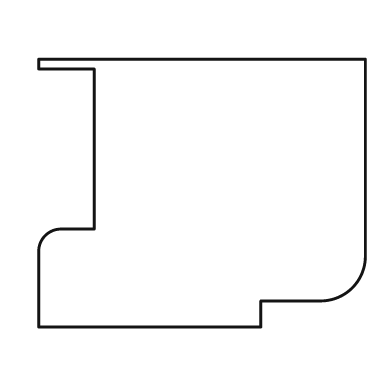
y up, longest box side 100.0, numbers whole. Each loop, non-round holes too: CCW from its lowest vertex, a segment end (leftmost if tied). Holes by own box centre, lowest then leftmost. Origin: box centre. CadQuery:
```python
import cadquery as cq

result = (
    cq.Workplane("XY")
    .moveTo(-50.0, -41.0)
    .lineTo(18.0, -41.0)
    .lineTo(18.0, -33.0)
    .lineTo(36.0, -33.0)
    .threePointArc((46.0, -29.0), (50.0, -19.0))
    .lineTo(50.0, 41.0)
    .lineTo(-50.0, 41.0)
    .lineTo(-50.0, 38.0)
    .lineTo(-33.0, 38.0)
    .lineTo(-33.0, -11.0)
    .lineTo(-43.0, -11.0)
    .threePointArc((-48.0, -13.0), (-50.0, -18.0))
    .close()
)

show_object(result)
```